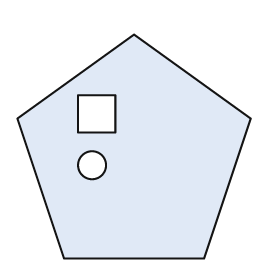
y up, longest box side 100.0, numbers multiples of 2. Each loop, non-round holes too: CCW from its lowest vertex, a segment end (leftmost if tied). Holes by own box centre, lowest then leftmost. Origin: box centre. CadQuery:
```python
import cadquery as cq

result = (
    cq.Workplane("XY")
    .moveTo(-30.0, -48.0)
    .lineTo(30.0, -48.0)
    .lineTo(50.0, 12.0)
    .lineTo(0.0, 48.0)
    .lineTo(-50.0, 12.0)
    .close()
    .moveTo(-18.0, -8.0)
    .circle(6.0)
    .moveTo(-24.0, 6.0)
    .lineTo(-8.0, 6.0)
    .lineTo(-8.0, 22.0)
    .lineTo(-24.0, 22.0)
    .close()
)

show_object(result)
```